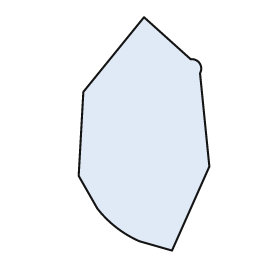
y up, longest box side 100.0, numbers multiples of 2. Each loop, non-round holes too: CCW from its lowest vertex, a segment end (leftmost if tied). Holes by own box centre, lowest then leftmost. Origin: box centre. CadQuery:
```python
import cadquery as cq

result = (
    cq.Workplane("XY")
    .moveTo(12.0, -50.0)
    .lineTo(28.0, -14.0)
    .lineTo(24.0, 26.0)
    .threePointArc((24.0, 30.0), (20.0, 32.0))
    .lineTo(0.0, 50.0)
    .lineTo(-26.0, 18.0)
    .lineTo(-28.0, -18.0)
    .lineTo(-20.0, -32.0)
    .threePointArc((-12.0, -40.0), (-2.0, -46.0))
    .close()
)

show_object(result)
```